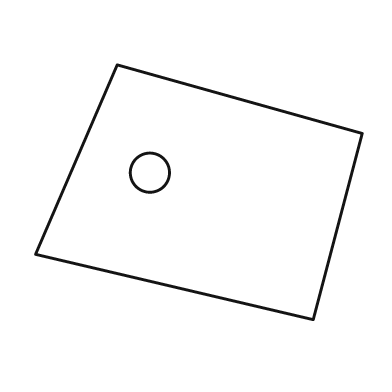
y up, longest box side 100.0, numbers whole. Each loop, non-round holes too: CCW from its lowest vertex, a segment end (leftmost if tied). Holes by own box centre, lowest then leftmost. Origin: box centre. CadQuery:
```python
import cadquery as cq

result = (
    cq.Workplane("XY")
    .moveTo(35.0, -39.0)
    .lineTo(50.0, 18.0)
    .lineTo(-25.0, 39.0)
    .lineTo(-50.0, -19.0)
    .close()
    .moveTo(-15.0, 6.0)
    .circle(6.0)
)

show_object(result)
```